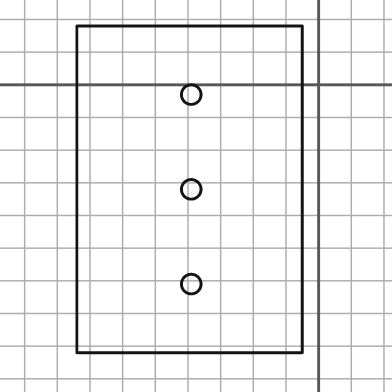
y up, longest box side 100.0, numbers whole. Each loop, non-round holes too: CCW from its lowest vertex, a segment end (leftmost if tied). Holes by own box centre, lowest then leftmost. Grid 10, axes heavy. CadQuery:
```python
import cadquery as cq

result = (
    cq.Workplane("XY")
    .moveTo(-74.0, -82.0)
    .lineTo(-5.0, -82.0)
    .lineTo(-5.0, 18.0)
    .lineTo(-74.0, 18.0)
    .close()
    .moveTo(-39.0, -61.0)
    .circle(3.0)
    .moveTo(-39.0, -32.0)
    .circle(3.0)
    .moveTo(-39.0, -3.0)
    .circle(3.0)
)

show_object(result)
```